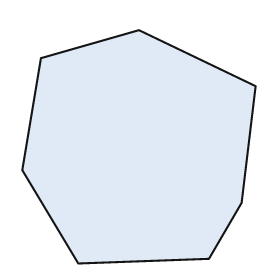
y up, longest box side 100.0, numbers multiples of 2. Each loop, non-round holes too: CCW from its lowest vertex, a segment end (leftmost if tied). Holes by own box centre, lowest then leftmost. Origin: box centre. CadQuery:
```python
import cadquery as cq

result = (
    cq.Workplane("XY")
    .moveTo(-26.0, -50.0)
    .lineTo(30.0, -48.0)
    .lineTo(44.0, -24.0)
    .lineTo(50.0, 26.0)
    .lineTo(0.0, 50.0)
    .lineTo(-42.0, 38.0)
    .lineTo(-50.0, -10.0)
    .close()
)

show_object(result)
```